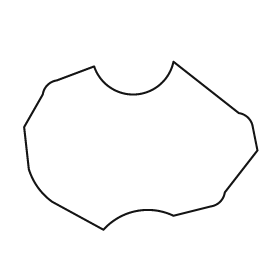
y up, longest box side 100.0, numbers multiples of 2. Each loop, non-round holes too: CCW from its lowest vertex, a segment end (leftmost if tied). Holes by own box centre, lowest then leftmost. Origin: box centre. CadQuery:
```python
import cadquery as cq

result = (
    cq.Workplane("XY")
    .moveTo(-16.0, -36.0)
    .threePointArc((-2.0, -28.0), (14.0, -30.0))
    .lineTo(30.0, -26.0)
    .threePointArc((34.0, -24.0), (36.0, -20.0))
    .lineTo(50.0, -2.0)
    .lineTo(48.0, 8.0)
    .threePointArc((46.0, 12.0), (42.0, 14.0))
    .lineTo(14.0, 36.0)
    .threePointArc((-2.0, 22.0), (-20.0, 34.0))
    .lineTo(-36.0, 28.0)
    .threePointArc((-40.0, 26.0), (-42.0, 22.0))
    .lineTo(-50.0, 8.0)
    .lineTo(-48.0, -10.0)
    .threePointArc((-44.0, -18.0), (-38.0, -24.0))
    .close()
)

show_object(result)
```